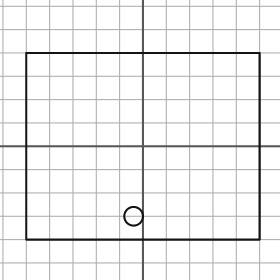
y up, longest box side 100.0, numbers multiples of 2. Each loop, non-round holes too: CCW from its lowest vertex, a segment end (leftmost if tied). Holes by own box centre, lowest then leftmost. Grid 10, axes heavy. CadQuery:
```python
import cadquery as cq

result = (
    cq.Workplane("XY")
    .moveTo(-50.0, -40.0)
    .lineTo(50.0, -40.0)
    .lineTo(50.0, 40.0)
    .lineTo(-50.0, 40.0)
    .close()
    .moveTo(-4.0, -30.0)
    .circle(4.0)
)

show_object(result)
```